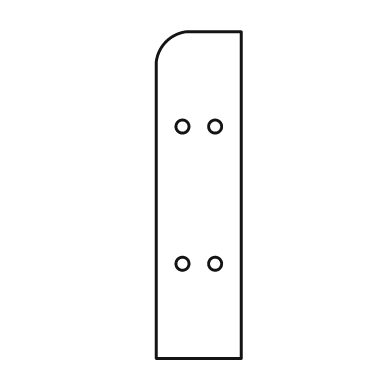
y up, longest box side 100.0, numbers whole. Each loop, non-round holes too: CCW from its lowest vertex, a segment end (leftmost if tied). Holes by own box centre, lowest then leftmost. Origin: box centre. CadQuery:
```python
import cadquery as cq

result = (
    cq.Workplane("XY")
    .moveTo(-13.0, -50.0)
    .lineTo(13.0, -50.0)
    .lineTo(13.0, 50.0)
    .lineTo(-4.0, 50.0)
    .threePointArc((-10.0, 47.0), (-13.0, 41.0))
    .close()
    .moveTo(-5.0, -21.0)
    .circle(2.0)
    .moveTo(5.0, -21.0)
    .circle(2.0)
    .moveTo(-5.0, 21.0)
    .circle(2.0)
    .moveTo(5.0, 21.0)
    .circle(2.0)
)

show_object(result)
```